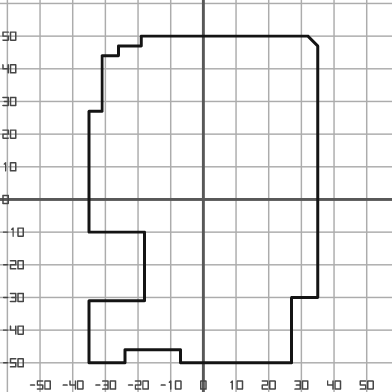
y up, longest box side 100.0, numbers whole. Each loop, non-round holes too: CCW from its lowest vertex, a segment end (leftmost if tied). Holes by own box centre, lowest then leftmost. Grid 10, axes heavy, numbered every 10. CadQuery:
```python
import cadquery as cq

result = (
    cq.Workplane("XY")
    .moveTo(-35.0, -50.0)
    .lineTo(-24.0, -50.0)
    .lineTo(-24.0, -46.0)
    .lineTo(-7.0, -46.0)
    .lineTo(-7.0, -50.0)
    .lineTo(27.0, -50.0)
    .lineTo(27.0, -30.0)
    .lineTo(35.0, -30.0)
    .lineTo(35.0, 47.0)
    .lineTo(32.0, 50.0)
    .lineTo(-19.0, 50.0)
    .lineTo(-19.0, 47.0)
    .lineTo(-26.0, 47.0)
    .lineTo(-26.0, 44.0)
    .lineTo(-31.0, 44.0)
    .lineTo(-31.0, 27.0)
    .lineTo(-35.0, 27.0)
    .lineTo(-35.0, -10.0)
    .lineTo(-18.0, -10.0)
    .lineTo(-18.0, -31.0)
    .lineTo(-35.0, -31.0)
    .close()
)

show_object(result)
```